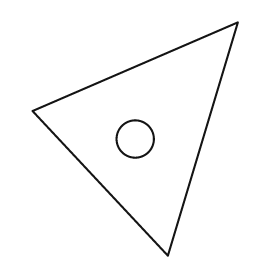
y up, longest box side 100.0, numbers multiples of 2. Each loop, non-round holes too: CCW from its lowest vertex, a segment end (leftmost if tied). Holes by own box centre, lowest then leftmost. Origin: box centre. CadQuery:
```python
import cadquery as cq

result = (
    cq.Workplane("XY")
    .moveTo(14.0, -50.0)
    .lineTo(44.0, 50.0)
    .lineTo(-44.0, 12.0)
    .close()
    .moveTo(0.0, 0.0)
    .circle(8.0)
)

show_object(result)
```